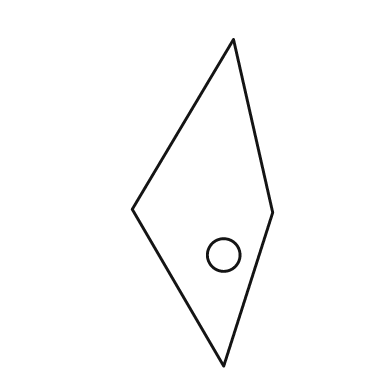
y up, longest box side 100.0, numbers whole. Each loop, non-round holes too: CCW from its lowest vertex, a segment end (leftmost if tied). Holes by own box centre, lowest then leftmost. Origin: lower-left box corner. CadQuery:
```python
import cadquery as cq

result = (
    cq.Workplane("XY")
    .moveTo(28.0, 0.0)
    .lineTo(43.0, 47.0)
    .lineTo(31.0, 100.0)
    .lineTo(0.0, 48.0)
    .close()
    .moveTo(28.0, 34.0)
    .circle(5.0)
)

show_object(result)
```